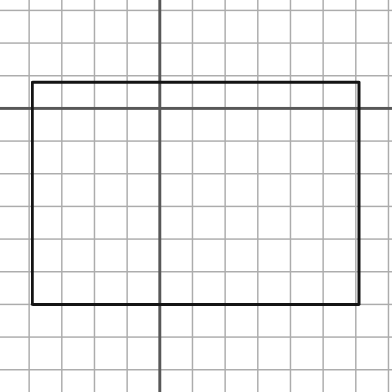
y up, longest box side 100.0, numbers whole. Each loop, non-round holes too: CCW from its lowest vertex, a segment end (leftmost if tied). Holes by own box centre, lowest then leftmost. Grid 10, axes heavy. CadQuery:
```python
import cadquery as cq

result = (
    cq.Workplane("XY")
    .moveTo(-39.0, -60.0)
    .lineTo(61.0, -60.0)
    .lineTo(61.0, 8.0)
    .lineTo(-39.0, 8.0)
    .close()
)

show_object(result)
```